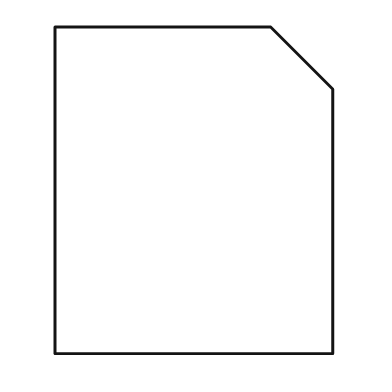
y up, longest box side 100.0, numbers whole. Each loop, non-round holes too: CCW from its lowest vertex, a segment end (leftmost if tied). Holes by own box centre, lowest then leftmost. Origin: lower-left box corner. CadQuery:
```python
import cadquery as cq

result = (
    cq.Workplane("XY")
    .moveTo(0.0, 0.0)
    .lineTo(85.0, 0.0)
    .lineTo(85.0, 81.0)
    .lineTo(66.0, 100.0)
    .lineTo(0.0, 100.0)
    .close()
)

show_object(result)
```